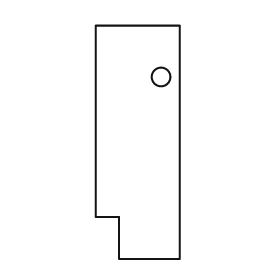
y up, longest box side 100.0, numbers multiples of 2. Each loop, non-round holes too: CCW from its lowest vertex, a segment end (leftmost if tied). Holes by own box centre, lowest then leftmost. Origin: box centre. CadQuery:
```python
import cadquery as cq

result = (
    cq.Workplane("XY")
    .moveTo(-8.0, -50.0)
    .lineTo(18.0, -50.0)
    .lineTo(18.0, 50.0)
    .lineTo(-18.0, 50.0)
    .lineTo(-18.0, -32.0)
    .lineTo(-8.0, -32.0)
    .close()
    .moveTo(10.0, 28.0)
    .circle(4.0)
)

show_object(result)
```